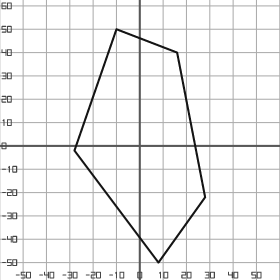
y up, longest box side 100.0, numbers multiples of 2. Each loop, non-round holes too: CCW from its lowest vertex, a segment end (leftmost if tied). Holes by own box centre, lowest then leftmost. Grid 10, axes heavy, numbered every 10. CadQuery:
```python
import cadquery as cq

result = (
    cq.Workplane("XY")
    .moveTo(8.0, -50.0)
    .lineTo(28.0, -22.0)
    .lineTo(16.0, 40.0)
    .lineTo(-10.0, 50.0)
    .lineTo(-28.0, -2.0)
    .close()
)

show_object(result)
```